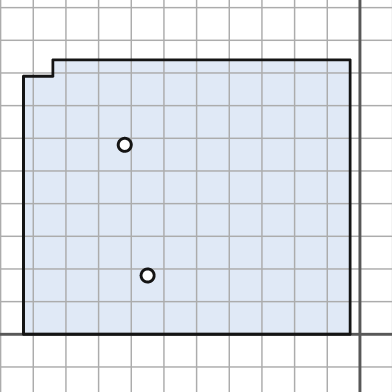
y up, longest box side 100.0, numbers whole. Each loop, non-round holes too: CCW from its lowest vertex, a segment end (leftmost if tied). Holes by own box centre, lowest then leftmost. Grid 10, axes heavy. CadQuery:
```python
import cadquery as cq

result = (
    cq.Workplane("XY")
    .moveTo(-103.0, 0.0)
    .lineTo(-3.0, 0.0)
    .lineTo(-3.0, 84.0)
    .lineTo(-94.0, 84.0)
    .lineTo(-94.0, 79.0)
    .lineTo(-103.0, 79.0)
    .close()
    .moveTo(-65.0, 18.0)
    .circle(2.0)
    .moveTo(-72.0, 58.0)
    .circle(2.0)
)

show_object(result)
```